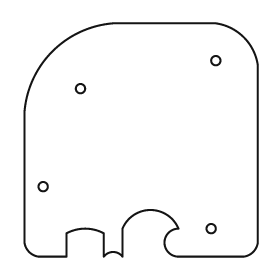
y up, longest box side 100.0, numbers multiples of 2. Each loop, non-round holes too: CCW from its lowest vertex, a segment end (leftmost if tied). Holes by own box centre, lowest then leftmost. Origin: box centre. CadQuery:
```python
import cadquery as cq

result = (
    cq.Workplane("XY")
    .moveTo(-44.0, -50.0)
    .lineTo(-32.0, -50.0)
    .lineTo(-32.0, -40.0)
    .threePointArc((-24.0, -38.0), (-16.0, -40.0))
    .lineTo(-16.0, -50.0)
    .threePointArc((-12.0, -48.0), (-8.0, -50.0))
    .lineTo(-8.0, -38.0)
    .threePointArc((4.0, -30.0), (16.0, -38.0))
    .threePointArc((10.0, -44.0), (16.0, -50.0))
    .lineTo(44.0, -50.0)
    .threePointArc((48.0, -48.0), (50.0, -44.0))
    .lineTo(50.0, 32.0)
    .threePointArc((44.0, 44.0), (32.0, 50.0))
    .lineTo(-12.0, 50.0)
    .threePointArc((-38.0, 38.0), (-50.0, 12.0))
    .lineTo(-50.0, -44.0)
    .threePointArc((-48.0, -48.0), (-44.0, -50.0))
    .close()
    .moveTo(30.0, -38.0)
    .circle(2.0)
    .moveTo(-42.0, -20.0)
    .circle(2.0)
    .moveTo(-26.0, 22.0)
    .circle(2.0)
    .moveTo(32.0, 34.0)
    .circle(2.0)
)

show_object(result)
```